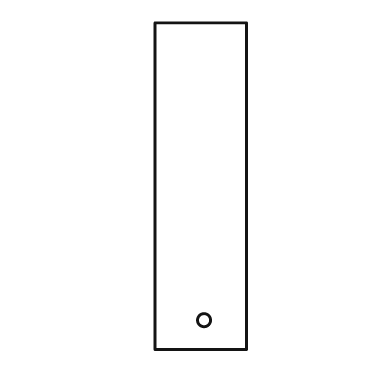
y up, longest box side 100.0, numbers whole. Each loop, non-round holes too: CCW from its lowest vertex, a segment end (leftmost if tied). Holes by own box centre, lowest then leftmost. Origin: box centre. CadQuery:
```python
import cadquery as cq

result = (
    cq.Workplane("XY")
    .moveTo(-14.0, -50.0)
    .lineTo(14.0, -50.0)
    .lineTo(14.0, 50.0)
    .lineTo(-14.0, 50.0)
    .close()
    .moveTo(1.0, -41.0)
    .circle(2.0)
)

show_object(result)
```